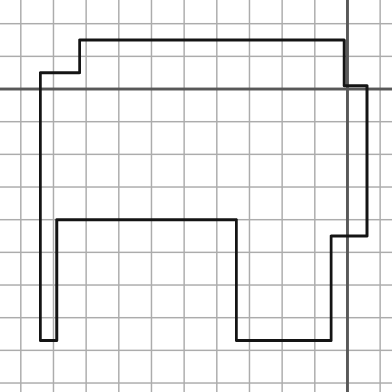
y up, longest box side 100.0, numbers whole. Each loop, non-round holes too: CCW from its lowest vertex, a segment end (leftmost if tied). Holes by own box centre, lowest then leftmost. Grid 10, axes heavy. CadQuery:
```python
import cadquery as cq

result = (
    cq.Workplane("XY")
    .moveTo(-94.0, -77.0)
    .lineTo(-89.0, -77.0)
    .lineTo(-89.0, -40.0)
    .lineTo(-34.0, -40.0)
    .lineTo(-34.0, -77.0)
    .lineTo(-5.0, -77.0)
    .lineTo(-5.0, -45.0)
    .lineTo(6.0, -45.0)
    .lineTo(6.0, 1.0)
    .lineTo(-1.0, 1.0)
    .lineTo(-1.0, 15.0)
    .lineTo(-82.0, 15.0)
    .lineTo(-82.0, 5.0)
    .lineTo(-94.0, 5.0)
    .close()
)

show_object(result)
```